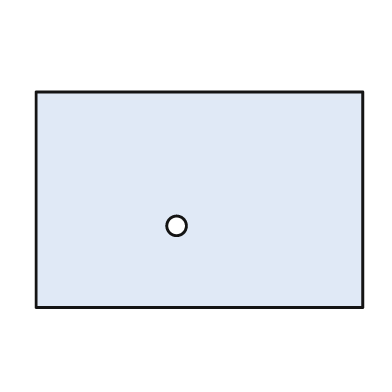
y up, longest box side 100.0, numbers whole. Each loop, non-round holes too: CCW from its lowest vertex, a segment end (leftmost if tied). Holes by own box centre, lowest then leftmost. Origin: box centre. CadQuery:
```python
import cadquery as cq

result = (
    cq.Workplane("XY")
    .moveTo(-50.0, -33.0)
    .lineTo(50.0, -33.0)
    .lineTo(50.0, 33.0)
    .lineTo(-50.0, 33.0)
    .close()
    .moveTo(-7.0, -8.0)
    .circle(3.0)
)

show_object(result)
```